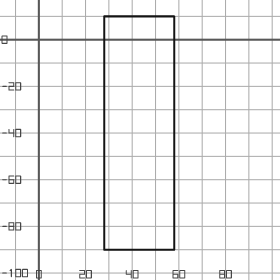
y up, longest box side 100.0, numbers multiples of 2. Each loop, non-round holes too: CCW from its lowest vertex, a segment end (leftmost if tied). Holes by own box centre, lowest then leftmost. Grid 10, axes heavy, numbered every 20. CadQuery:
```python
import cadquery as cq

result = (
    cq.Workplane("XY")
    .moveTo(28.0, -90.0)
    .lineTo(58.0, -90.0)
    .lineTo(58.0, 10.0)
    .lineTo(28.0, 10.0)
    .close()
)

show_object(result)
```